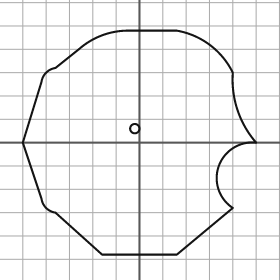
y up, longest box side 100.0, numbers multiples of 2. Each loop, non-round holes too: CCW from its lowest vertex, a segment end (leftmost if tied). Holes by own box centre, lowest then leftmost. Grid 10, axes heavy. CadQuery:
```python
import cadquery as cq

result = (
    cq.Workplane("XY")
    .moveTo(-16.0, -48.0)
    .lineTo(16.0, -48.0)
    .lineTo(40.0, -28.0)
    .threePointArc((34.0, -10.0), (50.0, 0.0))
    .threePointArc((42.0, 14.0), (40.0, 30.0))
    .threePointArc((30.0, 42.0), (16.0, 48.0))
    .lineTo(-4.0, 48.0)
    .threePointArc((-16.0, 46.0), (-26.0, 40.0))
    .lineTo(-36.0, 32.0)
    .threePointArc((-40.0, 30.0), (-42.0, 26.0))
    .lineTo(-50.0, 0.0)
    .lineTo(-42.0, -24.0)
    .threePointArc((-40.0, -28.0), (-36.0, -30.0))
    .close()
    .moveTo(-2.0, 6.0)
    .circle(2.0)
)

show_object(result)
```